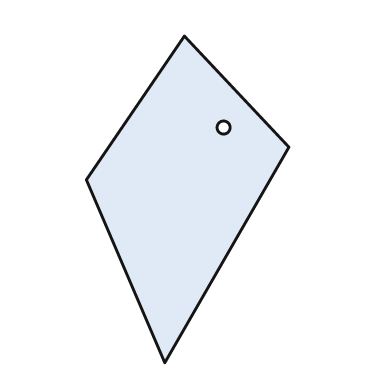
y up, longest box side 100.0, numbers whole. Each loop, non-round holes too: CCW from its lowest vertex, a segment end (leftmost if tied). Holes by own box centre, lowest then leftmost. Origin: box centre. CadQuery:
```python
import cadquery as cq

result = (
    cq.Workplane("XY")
    .moveTo(-7.0, -50.0)
    .lineTo(31.0, 16.0)
    .lineTo(-1.0, 50.0)
    .lineTo(-31.0, 6.0)
    .close()
    .moveTo(11.0, 22.0)
    .circle(2.0)
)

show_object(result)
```